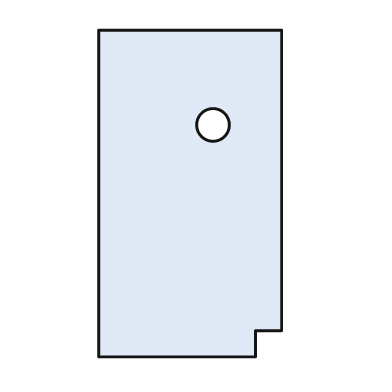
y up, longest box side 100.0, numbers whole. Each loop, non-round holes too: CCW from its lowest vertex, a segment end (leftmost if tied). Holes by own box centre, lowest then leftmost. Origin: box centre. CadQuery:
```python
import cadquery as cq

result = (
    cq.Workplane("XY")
    .moveTo(-28.0, -50.0)
    .lineTo(20.0, -50.0)
    .lineTo(20.0, -42.0)
    .lineTo(28.0, -42.0)
    .lineTo(28.0, 50.0)
    .lineTo(-28.0, 50.0)
    .close()
    .moveTo(7.0, 21.0)
    .circle(5.0)
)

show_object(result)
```